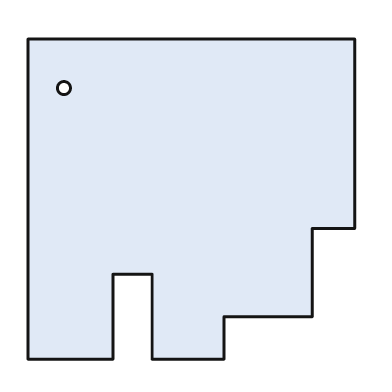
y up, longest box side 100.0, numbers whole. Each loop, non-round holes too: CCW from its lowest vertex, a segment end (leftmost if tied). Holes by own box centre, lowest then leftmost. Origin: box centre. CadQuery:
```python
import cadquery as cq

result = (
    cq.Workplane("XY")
    .moveTo(-50.0, -49.0)
    .lineTo(-24.0, -49.0)
    .lineTo(-24.0, -23.0)
    .lineTo(-12.0, -23.0)
    .lineTo(-12.0, -49.0)
    .lineTo(10.0, -49.0)
    .lineTo(10.0, -36.0)
    .lineTo(37.0, -36.0)
    .lineTo(37.0, -9.0)
    .lineTo(50.0, -9.0)
    .lineTo(50.0, 49.0)
    .lineTo(-50.0, 49.0)
    .close()
    .moveTo(-39.0, 34.0)
    .circle(2.0)
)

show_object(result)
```